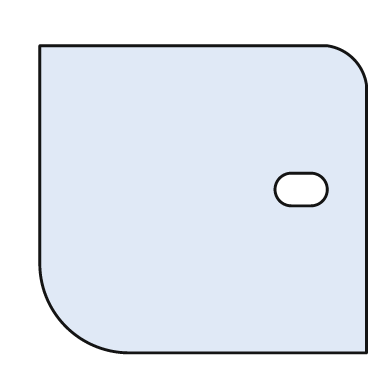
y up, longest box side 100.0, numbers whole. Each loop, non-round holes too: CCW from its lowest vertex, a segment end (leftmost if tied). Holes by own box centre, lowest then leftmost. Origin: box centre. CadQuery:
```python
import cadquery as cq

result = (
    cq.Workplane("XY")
    .moveTo(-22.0, -47.0)
    .lineTo(50.0, -47.0)
    .lineTo(50.0, 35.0)
    .threePointArc((46.0, 43.0), (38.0, 47.0))
    .lineTo(-50.0, 47.0)
    .lineTo(-50.0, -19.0)
    .threePointArc((-42.0, -39.0), (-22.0, -47.0))
    .close()
    .moveTo(27.0, -2.0)
    .lineTo(33.0, -2.0)
    .threePointArc((38.0, 3.0), (33.0, 8.0))
    .lineTo(27.0, 8.0)
    .threePointArc((22.0, 3.0), (27.0, -2.0))
    .close()
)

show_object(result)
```